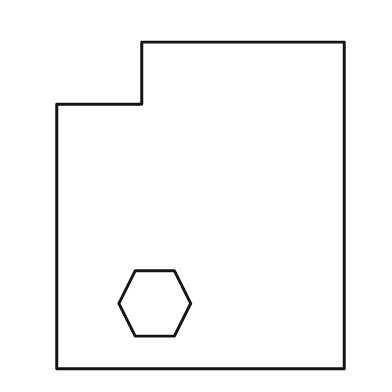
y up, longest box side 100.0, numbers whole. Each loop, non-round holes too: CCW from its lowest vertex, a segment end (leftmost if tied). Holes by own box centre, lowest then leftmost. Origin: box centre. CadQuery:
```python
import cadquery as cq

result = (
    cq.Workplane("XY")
    .moveTo(-44.0, -50.0)
    .lineTo(44.0, -50.0)
    .lineTo(44.0, 50.0)
    .lineTo(-18.0, 50.0)
    .lineTo(-18.0, 31.0)
    .lineTo(-44.0, 31.0)
    .close()
    .moveTo(-20.0, -40.0)
    .lineTo(-8.0, -40.0)
    .lineTo(-3.0, -30.0)
    .lineTo(-8.0, -20.0)
    .lineTo(-20.0, -20.0)
    .lineTo(-25.0, -30.0)
    .close()
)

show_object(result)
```